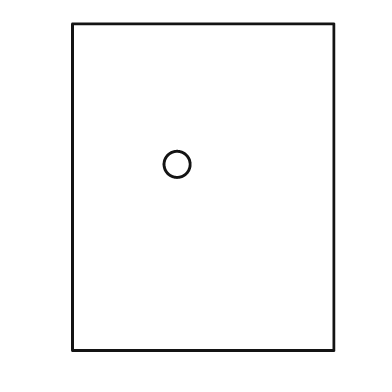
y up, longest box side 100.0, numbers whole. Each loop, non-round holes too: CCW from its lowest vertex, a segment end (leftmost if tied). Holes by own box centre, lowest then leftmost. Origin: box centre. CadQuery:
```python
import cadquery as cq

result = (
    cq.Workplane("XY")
    .moveTo(-40.0, -50.0)
    .lineTo(40.0, -50.0)
    .lineTo(40.0, 50.0)
    .lineTo(-40.0, 50.0)
    .close()
    .moveTo(-8.0, 7.0)
    .circle(4.0)
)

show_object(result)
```